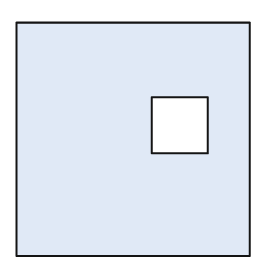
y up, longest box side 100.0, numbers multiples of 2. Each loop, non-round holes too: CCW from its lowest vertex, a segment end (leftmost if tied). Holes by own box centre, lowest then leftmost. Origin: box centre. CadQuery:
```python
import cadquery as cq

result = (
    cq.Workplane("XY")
    .moveTo(-50.0, -50.0)
    .lineTo(50.0, -50.0)
    .lineTo(50.0, 50.0)
    .lineTo(-50.0, 50.0)
    .close()
    .moveTo(8.0, -6.0)
    .lineTo(32.0, -6.0)
    .lineTo(32.0, 18.0)
    .lineTo(8.0, 18.0)
    .close()
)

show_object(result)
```